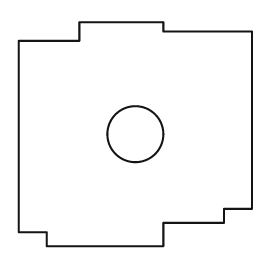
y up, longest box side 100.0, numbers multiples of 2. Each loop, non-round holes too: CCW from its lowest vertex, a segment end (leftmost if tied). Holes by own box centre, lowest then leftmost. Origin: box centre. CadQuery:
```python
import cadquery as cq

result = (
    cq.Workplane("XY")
    .moveTo(-38.0, -48.0)
    .lineTo(12.0, -48.0)
    .lineTo(12.0, -38.0)
    .lineTo(38.0, -38.0)
    .lineTo(38.0, -32.0)
    .lineTo(50.0, -32.0)
    .lineTo(50.0, 44.0)
    .lineTo(12.0, 44.0)
    .lineTo(12.0, 48.0)
    .lineTo(-24.0, 48.0)
    .lineTo(-24.0, 40.0)
    .lineTo(-50.0, 40.0)
    .lineTo(-50.0, -42.0)
    .lineTo(-38.0, -42.0)
    .close()
    .moveTo(0.0, 0.0)
    .circle(12.0)
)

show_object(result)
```